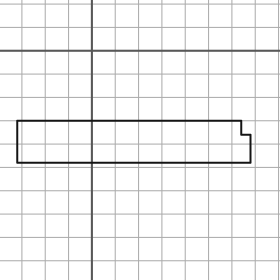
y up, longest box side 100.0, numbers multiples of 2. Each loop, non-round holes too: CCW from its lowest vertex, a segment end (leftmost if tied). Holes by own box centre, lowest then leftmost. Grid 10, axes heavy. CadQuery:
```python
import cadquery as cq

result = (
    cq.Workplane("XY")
    .moveTo(-32.0, -48.0)
    .lineTo(68.0, -48.0)
    .lineTo(68.0, -36.0)
    .lineTo(64.0, -36.0)
    .lineTo(64.0, -30.0)
    .lineTo(-32.0, -30.0)
    .close()
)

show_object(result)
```